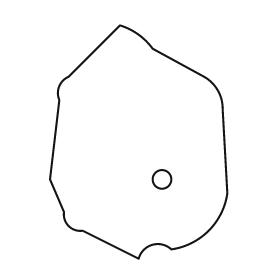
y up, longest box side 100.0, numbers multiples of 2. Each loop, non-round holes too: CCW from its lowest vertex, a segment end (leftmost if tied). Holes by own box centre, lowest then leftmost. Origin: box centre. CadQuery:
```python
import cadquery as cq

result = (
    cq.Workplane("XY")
    .moveTo(0.0, -50.0)
    .threePointArc((6.0, -44.0), (14.0, -46.0))
    .threePointArc((30.0, -38.0), (38.0, -22.0))
    .lineTo(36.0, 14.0)
    .threePointArc((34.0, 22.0), (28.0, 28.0))
    .lineTo(6.0, 40.0)
    .threePointArc((0.0, 46.0), (-8.0, 50.0))
    .lineTo(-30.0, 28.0)
    .threePointArc((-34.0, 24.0), (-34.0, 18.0))
    .lineTo(-38.0, -16.0)
    .lineTo(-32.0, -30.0)
    .threePointArc((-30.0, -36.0), (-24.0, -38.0))
    .close()
    .moveTo(10.0, -16.0)
    .circle(4.0)
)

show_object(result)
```